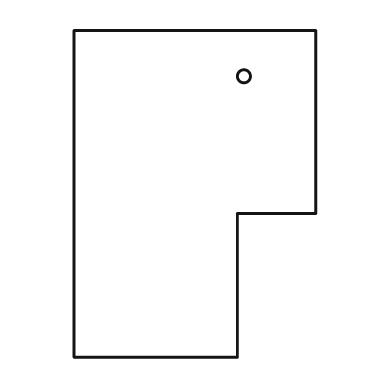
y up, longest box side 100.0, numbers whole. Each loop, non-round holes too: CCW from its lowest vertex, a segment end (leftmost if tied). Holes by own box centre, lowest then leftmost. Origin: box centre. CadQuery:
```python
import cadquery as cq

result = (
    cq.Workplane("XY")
    .moveTo(-37.0, -50.0)
    .lineTo(13.0, -50.0)
    .lineTo(13.0, -6.0)
    .lineTo(37.0, -6.0)
    .lineTo(37.0, 50.0)
    .lineTo(-37.0, 50.0)
    .close()
    .moveTo(15.0, 36.0)
    .circle(2.0)
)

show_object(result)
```